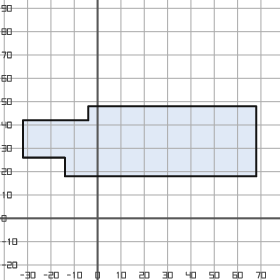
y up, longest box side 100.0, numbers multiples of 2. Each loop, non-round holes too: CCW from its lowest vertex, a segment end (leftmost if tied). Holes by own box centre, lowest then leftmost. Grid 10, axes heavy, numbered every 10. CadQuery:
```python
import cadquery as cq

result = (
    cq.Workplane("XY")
    .moveTo(-14.0, 18.0)
    .lineTo(68.0, 18.0)
    .lineTo(68.0, 48.0)
    .lineTo(-4.0, 48.0)
    .lineTo(-4.0, 42.0)
    .lineTo(-32.0, 42.0)
    .lineTo(-32.0, 26.0)
    .lineTo(-14.0, 26.0)
    .close()
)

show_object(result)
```